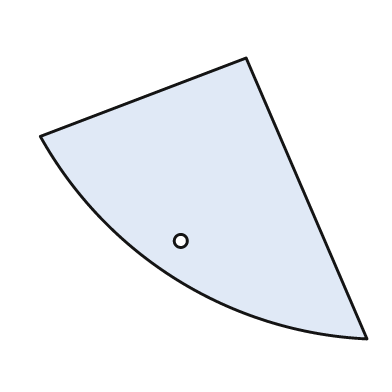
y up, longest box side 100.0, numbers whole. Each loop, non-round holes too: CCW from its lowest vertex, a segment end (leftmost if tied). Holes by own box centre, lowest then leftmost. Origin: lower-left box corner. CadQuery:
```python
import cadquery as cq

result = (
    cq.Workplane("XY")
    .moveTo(100.0, 0.0)
    .lineTo(63.0, 86.0)
    .lineTo(0.0, 62.0)
    .threePointArc((42.0, 18.0), (100.0, 0.0))
    .close()
    .moveTo(43.0, 30.0)
    .circle(2.0)
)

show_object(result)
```